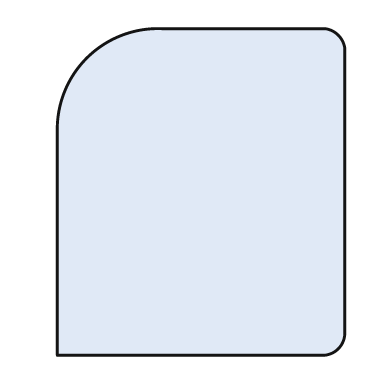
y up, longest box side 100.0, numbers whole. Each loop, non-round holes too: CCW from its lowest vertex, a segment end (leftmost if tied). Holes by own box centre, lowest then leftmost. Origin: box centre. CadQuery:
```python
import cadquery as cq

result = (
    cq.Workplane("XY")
    .moveTo(-44.0, -50.0)
    .lineTo(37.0, -50.0)
    .threePointArc((42.0, -48.0), (44.0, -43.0))
    .lineTo(44.0, 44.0)
    .threePointArc((42.0, 48.0), (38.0, 50.0))
    .lineTo(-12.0, 50.0)
    .threePointArc((-35.0, 41.0), (-44.0, 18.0))
    .close()
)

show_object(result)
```